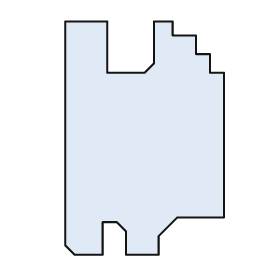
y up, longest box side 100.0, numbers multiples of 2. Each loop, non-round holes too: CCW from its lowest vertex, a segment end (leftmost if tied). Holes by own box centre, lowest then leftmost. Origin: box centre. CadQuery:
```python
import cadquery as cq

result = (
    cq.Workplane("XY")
    .moveTo(-30.0, -50.0)
    .lineTo(-18.0, -50.0)
    .lineTo(-18.0, -36.0)
    .lineTo(-12.0, -36.0)
    .lineTo(-8.0, -40.0)
    .lineTo(-8.0, -50.0)
    .lineTo(6.0, -50.0)
    .lineTo(6.0, -42.0)
    .lineTo(14.0, -34.0)
    .lineTo(34.0, -34.0)
    .lineTo(34.0, 28.0)
    .lineTo(28.0, 28.0)
    .lineTo(28.0, 36.0)
    .lineTo(22.0, 36.0)
    .lineTo(22.0, 44.0)
    .lineTo(12.0, 44.0)
    .lineTo(12.0, 50.0)
    .lineTo(4.0, 50.0)
    .lineTo(4.0, 32.0)
    .lineTo(0.0, 28.0)
    .lineTo(-16.0, 28.0)
    .lineTo(-16.0, 50.0)
    .lineTo(-34.0, 50.0)
    .lineTo(-34.0, -46.0)
    .close()
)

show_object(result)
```